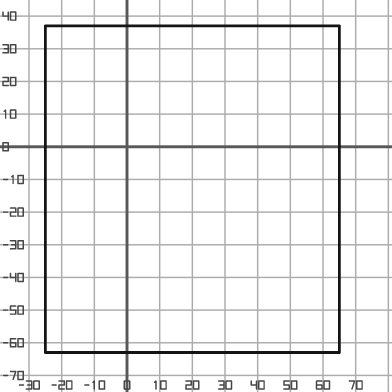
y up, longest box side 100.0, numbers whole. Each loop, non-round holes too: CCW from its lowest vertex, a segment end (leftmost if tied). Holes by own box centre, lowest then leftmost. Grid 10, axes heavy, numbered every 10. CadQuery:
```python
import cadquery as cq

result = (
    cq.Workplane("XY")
    .moveTo(-25.0, -63.0)
    .lineTo(65.0, -63.0)
    .lineTo(65.0, 37.0)
    .lineTo(-25.0, 37.0)
    .close()
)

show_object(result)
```